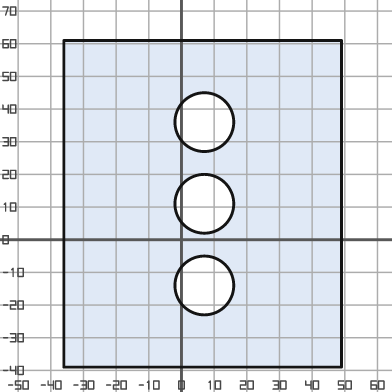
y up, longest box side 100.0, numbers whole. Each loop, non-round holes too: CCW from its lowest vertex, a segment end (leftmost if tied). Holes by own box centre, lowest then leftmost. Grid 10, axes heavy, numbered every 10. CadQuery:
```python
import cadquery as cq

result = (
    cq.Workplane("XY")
    .moveTo(-36.0, -39.0)
    .lineTo(49.0, -39.0)
    .lineTo(49.0, 61.0)
    .lineTo(-36.0, 61.0)
    .close()
    .moveTo(7.0, -14.0)
    .circle(9.0)
    .moveTo(7.0, 11.0)
    .circle(9.0)
    .moveTo(7.0, 36.0)
    .circle(9.0)
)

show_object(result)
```